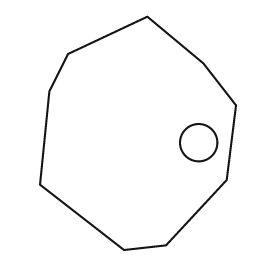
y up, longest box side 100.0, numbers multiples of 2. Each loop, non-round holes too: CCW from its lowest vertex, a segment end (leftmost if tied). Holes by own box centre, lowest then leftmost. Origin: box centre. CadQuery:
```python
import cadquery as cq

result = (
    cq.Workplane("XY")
    .moveTo(-6.0, -50.0)
    .lineTo(12.0, -48.0)
    .lineTo(38.0, -20.0)
    .lineTo(42.0, 12.0)
    .lineTo(28.0, 30.0)
    .lineTo(4.0, 50.0)
    .lineTo(-30.0, 34.0)
    .lineTo(-38.0, 18.0)
    .lineTo(-42.0, -22.0)
    .close()
    .moveTo(26.0, -4.0)
    .circle(8.0)
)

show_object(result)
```